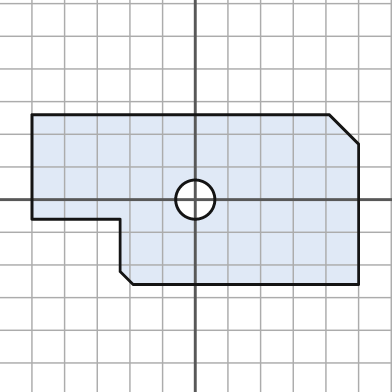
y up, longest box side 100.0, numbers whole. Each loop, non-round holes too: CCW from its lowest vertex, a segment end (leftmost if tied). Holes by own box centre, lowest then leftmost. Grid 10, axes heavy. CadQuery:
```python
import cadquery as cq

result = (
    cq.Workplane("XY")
    .moveTo(-19.0, -26.0)
    .lineTo(50.0, -26.0)
    .lineTo(50.0, 17.0)
    .lineTo(41.0, 26.0)
    .lineTo(-50.0, 26.0)
    .lineTo(-50.0, -6.0)
    .lineTo(-23.0, -6.0)
    .lineTo(-23.0, -22.0)
    .close()
    .moveTo(0.0, 0.0)
    .circle(6.0)
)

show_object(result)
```